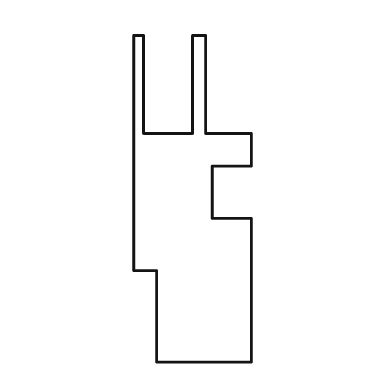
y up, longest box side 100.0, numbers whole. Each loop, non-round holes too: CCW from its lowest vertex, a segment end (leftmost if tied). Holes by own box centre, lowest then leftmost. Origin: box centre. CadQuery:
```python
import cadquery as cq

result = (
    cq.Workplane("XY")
    .moveTo(-11.0, -50.0)
    .lineTo(18.0, -50.0)
    .lineTo(18.0, -6.0)
    .lineTo(6.0, -6.0)
    .lineTo(6.0, 10.0)
    .lineTo(18.0, 10.0)
    .lineTo(18.0, 20.0)
    .lineTo(4.0, 20.0)
    .lineTo(4.0, 50.0)
    .lineTo(0.0, 50.0)
    .lineTo(0.0, 20.0)
    .lineTo(-15.0, 20.0)
    .lineTo(-15.0, 50.0)
    .lineTo(-18.0, 50.0)
    .lineTo(-18.0, -22.0)
    .lineTo(-11.0, -22.0)
    .close()
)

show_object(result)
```